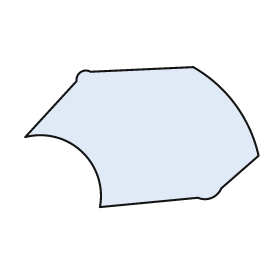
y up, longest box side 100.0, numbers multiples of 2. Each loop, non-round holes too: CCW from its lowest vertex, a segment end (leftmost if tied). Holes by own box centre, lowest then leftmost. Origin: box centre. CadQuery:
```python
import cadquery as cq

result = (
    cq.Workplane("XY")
    .moveTo(-18.0, -30.0)
    .lineTo(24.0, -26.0)
    .threePointArc((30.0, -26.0), (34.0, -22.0))
    .lineTo(50.0, -8.0)
    .threePointArc((40.0, 14.0), (22.0, 30.0))
    .lineTo(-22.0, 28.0)
    .threePointArc((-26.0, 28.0), (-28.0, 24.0))
    .lineTo(-50.0, 0.0)
    .threePointArc((-26.0, -6.0), (-18.0, -30.0))
    .close()
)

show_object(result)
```